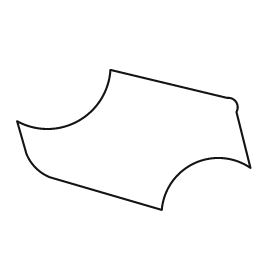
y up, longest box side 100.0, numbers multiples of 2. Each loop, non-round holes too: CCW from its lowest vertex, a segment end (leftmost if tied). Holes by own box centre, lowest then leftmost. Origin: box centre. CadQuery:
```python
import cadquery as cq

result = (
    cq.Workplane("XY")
    .moveTo(12.0, -30.0)
    .threePointArc((26.0, -10.0), (50.0, -12.0))
    .lineTo(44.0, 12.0)
    .threePointArc((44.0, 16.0), (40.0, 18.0))
    .lineTo(-10.0, 30.0)
    .threePointArc((-24.0, 8.0), (-50.0, 8.0))
    .lineTo(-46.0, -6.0)
    .threePointArc((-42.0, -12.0), (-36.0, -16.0))
    .close()
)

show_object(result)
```